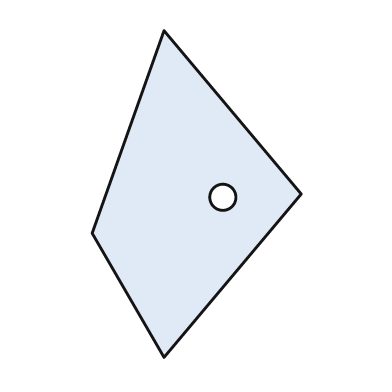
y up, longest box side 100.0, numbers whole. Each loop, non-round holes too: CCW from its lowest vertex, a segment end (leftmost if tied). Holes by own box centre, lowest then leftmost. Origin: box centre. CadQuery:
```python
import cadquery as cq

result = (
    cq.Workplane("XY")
    .moveTo(-10.0, -50.0)
    .lineTo(32.0, 0.0)
    .lineTo(-10.0, 50.0)
    .lineTo(-32.0, -12.0)
    .close()
    .moveTo(8.0, -1.0)
    .circle(4.0)
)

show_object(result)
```